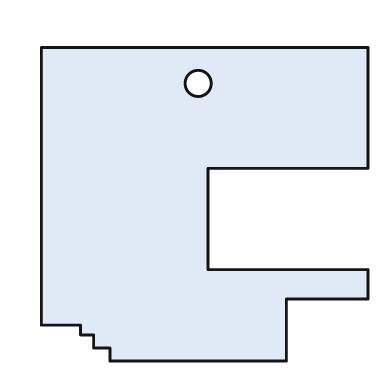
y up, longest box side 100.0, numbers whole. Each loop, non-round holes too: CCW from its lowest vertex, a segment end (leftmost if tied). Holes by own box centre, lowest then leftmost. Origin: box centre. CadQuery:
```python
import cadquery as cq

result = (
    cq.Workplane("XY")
    .moveTo(-29.0, -48.0)
    .lineTo(25.0, -48.0)
    .lineTo(25.0, -29.0)
    .lineTo(50.0, -29.0)
    .lineTo(50.0, -20.0)
    .lineTo(1.0, -20.0)
    .lineTo(1.0, 11.0)
    .lineTo(50.0, 11.0)
    .lineTo(50.0, 48.0)
    .lineTo(-50.0, 48.0)
    .lineTo(-50.0, -37.0)
    .lineTo(-38.0, -37.0)
    .lineTo(-38.0, -40.0)
    .lineTo(-34.0, -40.0)
    .lineTo(-34.0, -44.0)
    .lineTo(-29.0, -44.0)
    .close()
    .moveTo(-2.0, 37.0)
    .circle(4.0)
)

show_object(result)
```